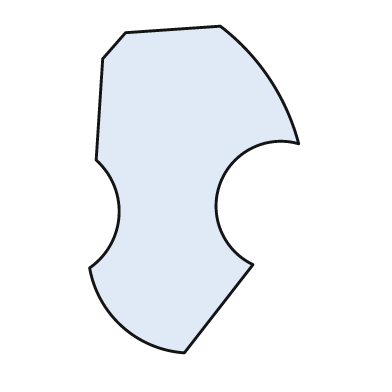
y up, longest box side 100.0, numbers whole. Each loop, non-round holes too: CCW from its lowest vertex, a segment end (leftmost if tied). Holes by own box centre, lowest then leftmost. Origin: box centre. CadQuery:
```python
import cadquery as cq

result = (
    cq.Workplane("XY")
    .moveTo(-3.0, -50.0)
    .lineTo(18.0, -23.0)
    .threePointArc((8.0, 2.0), (32.0, 14.0))
    .threePointArc((23.0, 34.0), (8.0, 50.0))
    .lineTo(-21.0, 48.0)
    .lineTo(-28.0, 40.0)
    .lineTo(-30.0, 9.0)
    .threePointArc((-23.0, -8.0), (-32.0, -24.0))
    .threePointArc((-22.0, -42.0), (-3.0, -50.0))
    .close()
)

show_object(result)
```